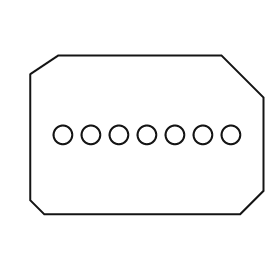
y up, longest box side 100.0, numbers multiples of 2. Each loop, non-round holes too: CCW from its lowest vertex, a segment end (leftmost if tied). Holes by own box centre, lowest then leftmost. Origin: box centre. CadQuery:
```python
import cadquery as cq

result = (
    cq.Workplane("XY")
    .moveTo(-44.0, -34.0)
    .lineTo(40.0, -34.0)
    .lineTo(50.0, -24.0)
    .lineTo(50.0, 16.0)
    .lineTo(32.0, 34.0)
    .lineTo(-38.0, 34.0)
    .lineTo(-50.0, 26.0)
    .lineTo(-50.0, -28.0)
    .close()
    .moveTo(-36.0, 0.0)
    .circle(4.0)
    .moveTo(-24.0, 0.0)
    .circle(4.0)
    .moveTo(-12.0, 0.0)
    .circle(4.0)
    .moveTo(0.0, 0.0)
    .circle(4.0)
    .moveTo(12.0, 0.0)
    .circle(4.0)
    .moveTo(24.0, 0.0)
    .circle(4.0)
    .moveTo(36.0, 0.0)
    .circle(4.0)
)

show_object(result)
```